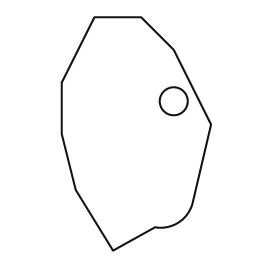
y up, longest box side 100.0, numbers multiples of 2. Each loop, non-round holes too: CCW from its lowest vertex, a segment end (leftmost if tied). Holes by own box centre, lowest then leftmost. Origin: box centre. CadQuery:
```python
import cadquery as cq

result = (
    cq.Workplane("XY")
    .moveTo(-10.0, -50.0)
    .lineTo(8.0, -40.0)
    .threePointArc((18.0, -38.0), (24.0, -30.0))
    .lineTo(32.0, 4.0)
    .lineTo(16.0, 36.0)
    .lineTo(2.0, 50.0)
    .lineTo(-18.0, 50.0)
    .lineTo(-32.0, 22.0)
    .lineTo(-32.0, 0.0)
    .lineTo(-26.0, -24.0)
    .close()
    .moveTo(16.0, 14.0)
    .circle(6.0)
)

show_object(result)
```